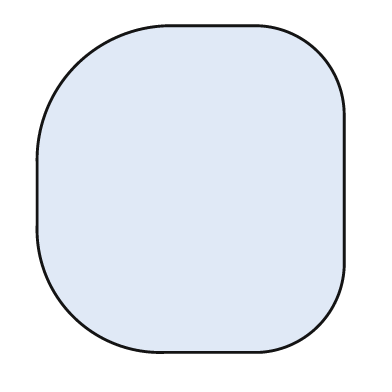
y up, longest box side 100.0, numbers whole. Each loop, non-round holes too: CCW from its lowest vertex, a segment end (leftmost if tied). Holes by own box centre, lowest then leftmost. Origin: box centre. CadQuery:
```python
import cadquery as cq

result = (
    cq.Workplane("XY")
    .moveTo(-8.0, -50.0)
    .lineTo(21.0, -50.0)
    .threePointArc((39.0, -42.0), (47.0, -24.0))
    .lineTo(47.0, 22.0)
    .threePointArc((39.0, 42.0), (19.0, 50.0))
    .lineTo(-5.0, 50.0)
    .threePointArc((-35.0, 38.0), (-47.0, 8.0))
    .lineTo(-47.0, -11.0)
    .threePointArc((-36.0, -39.0), (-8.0, -50.0))
    .close()
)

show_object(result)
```